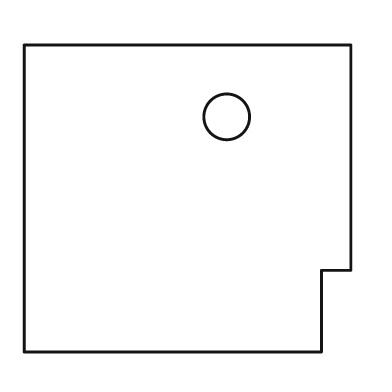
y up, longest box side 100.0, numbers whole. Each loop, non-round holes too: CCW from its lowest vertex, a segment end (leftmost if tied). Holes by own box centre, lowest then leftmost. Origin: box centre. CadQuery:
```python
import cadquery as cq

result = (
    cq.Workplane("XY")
    .moveTo(-50.0, -47.0)
    .lineTo(41.0, -47.0)
    .lineTo(41.0, -22.0)
    .lineTo(50.0, -22.0)
    .lineTo(50.0, 47.0)
    .lineTo(-50.0, 47.0)
    .close()
    .moveTo(12.0, 25.0)
    .circle(7.0)
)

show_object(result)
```